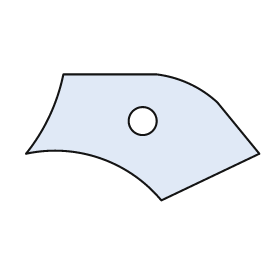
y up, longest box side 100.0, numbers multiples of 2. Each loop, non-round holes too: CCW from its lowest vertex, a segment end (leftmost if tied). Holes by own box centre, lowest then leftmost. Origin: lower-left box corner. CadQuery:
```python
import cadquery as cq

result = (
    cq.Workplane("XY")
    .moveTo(58.0, 0.0)
    .lineTo(100.0, 20.0)
    .lineTo(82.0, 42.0)
    .threePointArc((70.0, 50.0), (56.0, 54.0))
    .lineTo(16.0, 54.0)
    .threePointArc((10.0, 36.0), (0.0, 20.0))
    .threePointArc((32.0, 18.0), (58.0, 0.0))
    .close()
    .moveTo(50.0, 34.0)
    .circle(6.0)
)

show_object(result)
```